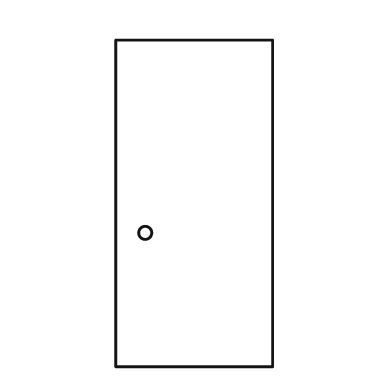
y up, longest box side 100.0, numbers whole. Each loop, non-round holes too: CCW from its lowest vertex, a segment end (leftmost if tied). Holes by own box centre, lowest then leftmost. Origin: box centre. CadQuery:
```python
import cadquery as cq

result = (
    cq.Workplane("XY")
    .moveTo(-24.0, -50.0)
    .lineTo(24.0, -50.0)
    .lineTo(24.0, 50.0)
    .lineTo(-24.0, 50.0)
    .close()
    .moveTo(-15.0, -9.0)
    .circle(2.0)
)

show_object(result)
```